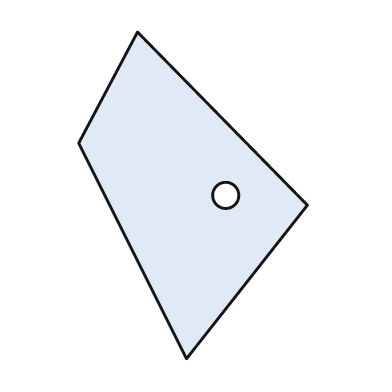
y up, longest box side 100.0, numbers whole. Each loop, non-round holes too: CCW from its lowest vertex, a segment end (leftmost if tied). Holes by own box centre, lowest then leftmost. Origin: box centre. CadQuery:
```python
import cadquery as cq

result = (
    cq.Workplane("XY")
    .moveTo(-2.0, -50.0)
    .lineTo(35.0, -3.0)
    .lineTo(-17.0, 50.0)
    .lineTo(-35.0, 16.0)
    .close()
    .moveTo(10.0, 0.0)
    .circle(4.0)
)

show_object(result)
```